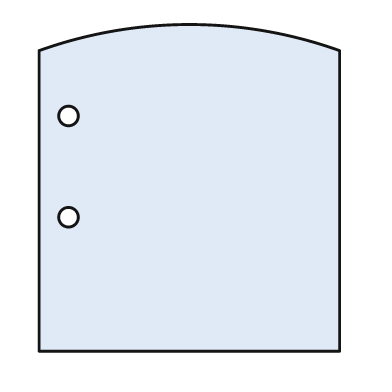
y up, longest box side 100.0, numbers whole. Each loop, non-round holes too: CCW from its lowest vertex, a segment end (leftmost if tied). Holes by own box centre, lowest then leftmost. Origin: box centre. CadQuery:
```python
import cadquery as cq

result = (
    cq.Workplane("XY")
    .moveTo(-46.0, -50.0)
    .lineTo(46.0, -50.0)
    .lineTo(46.0, 42.0)
    .threePointArc((0.0, 50.0), (-46.0, 42.0))
    .close()
    .moveTo(-37.0, -9.0)
    .circle(3.0)
    .moveTo(-37.0, 22.0)
    .circle(3.0)
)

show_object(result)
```